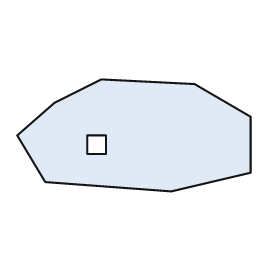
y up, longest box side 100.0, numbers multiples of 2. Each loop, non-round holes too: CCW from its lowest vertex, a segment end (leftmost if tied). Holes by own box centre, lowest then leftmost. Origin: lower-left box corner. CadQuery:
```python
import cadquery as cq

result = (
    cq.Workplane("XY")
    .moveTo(66.0, 0.0)
    .lineTo(100.0, 8.0)
    .lineTo(100.0, 32.0)
    .lineTo(76.0, 46.0)
    .lineTo(36.0, 48.0)
    .lineTo(16.0, 38.0)
    .lineTo(0.0, 24.0)
    .lineTo(12.0, 4.0)
    .close()
    .moveTo(30.0, 16.0)
    .lineTo(38.0, 16.0)
    .lineTo(38.0, 24.0)
    .lineTo(30.0, 24.0)
    .close()
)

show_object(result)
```